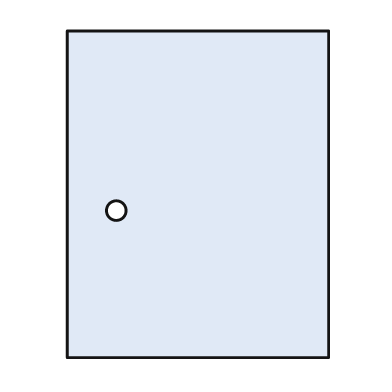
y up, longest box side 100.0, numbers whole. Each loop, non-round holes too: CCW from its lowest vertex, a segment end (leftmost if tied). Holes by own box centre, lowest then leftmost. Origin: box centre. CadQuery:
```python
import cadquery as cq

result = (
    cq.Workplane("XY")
    .moveTo(-40.0, -50.0)
    .lineTo(40.0, -50.0)
    .lineTo(40.0, 50.0)
    .lineTo(-40.0, 50.0)
    .close()
    .moveTo(-25.0, -5.0)
    .circle(3.0)
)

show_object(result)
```